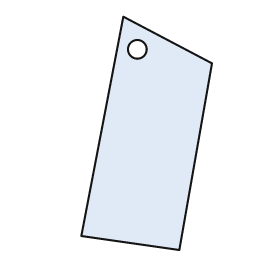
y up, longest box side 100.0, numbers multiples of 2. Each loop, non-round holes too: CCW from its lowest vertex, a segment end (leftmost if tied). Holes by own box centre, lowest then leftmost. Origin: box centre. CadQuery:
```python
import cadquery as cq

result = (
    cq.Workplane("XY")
    .moveTo(14.0, -50.0)
    .lineTo(28.0, 30.0)
    .lineTo(-10.0, 50.0)
    .lineTo(-28.0, -44.0)
    .close()
    .moveTo(-4.0, 36.0)
    .circle(4.0)
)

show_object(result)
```